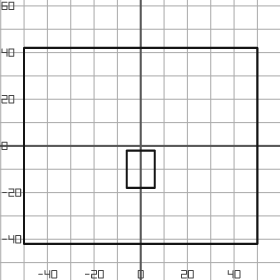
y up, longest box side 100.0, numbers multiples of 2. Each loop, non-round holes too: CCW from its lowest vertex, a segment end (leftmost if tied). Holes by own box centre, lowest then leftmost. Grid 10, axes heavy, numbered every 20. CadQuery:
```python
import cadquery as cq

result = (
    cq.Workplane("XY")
    .moveTo(-50.0, -42.0)
    .lineTo(50.0, -42.0)
    .lineTo(50.0, 42.0)
    .lineTo(-50.0, 42.0)
    .close()
    .moveTo(-6.0, -18.0)
    .lineTo(6.0, -18.0)
    .lineTo(6.0, -2.0)
    .lineTo(-6.0, -2.0)
    .close()
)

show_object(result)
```